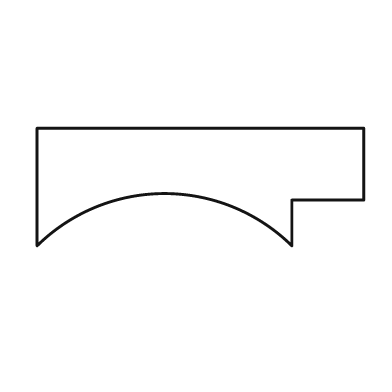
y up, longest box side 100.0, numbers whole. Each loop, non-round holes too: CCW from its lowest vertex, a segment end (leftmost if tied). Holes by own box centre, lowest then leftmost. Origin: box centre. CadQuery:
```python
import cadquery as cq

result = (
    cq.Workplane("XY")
    .moveTo(-50.0, -18.0)
    .threePointArc((-11.0, -2.0), (28.0, -18.0))
    .lineTo(28.0, -4.0)
    .lineTo(50.0, -4.0)
    .lineTo(50.0, 18.0)
    .lineTo(-50.0, 18.0)
    .close()
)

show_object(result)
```